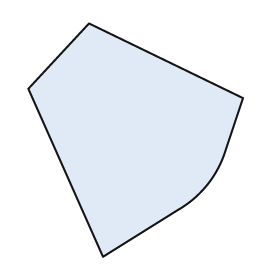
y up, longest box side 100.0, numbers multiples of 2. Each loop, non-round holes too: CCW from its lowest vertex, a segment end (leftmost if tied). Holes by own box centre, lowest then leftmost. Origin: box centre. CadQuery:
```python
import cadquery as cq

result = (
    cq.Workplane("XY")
    .moveTo(-14.0, -50.0)
    .lineTo(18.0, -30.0)
    .threePointArc((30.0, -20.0), (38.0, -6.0))
    .lineTo(46.0, 18.0)
    .lineTo(-20.0, 50.0)
    .lineTo(-46.0, 22.0)
    .close()
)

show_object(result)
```